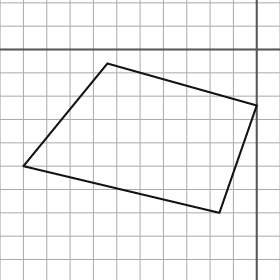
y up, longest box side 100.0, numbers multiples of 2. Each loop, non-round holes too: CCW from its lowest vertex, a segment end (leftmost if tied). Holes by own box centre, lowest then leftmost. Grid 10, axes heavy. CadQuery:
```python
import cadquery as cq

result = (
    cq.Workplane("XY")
    .moveTo(-16.0, -70.0)
    .lineTo(0.0, -24.0)
    .lineTo(-64.0, -6.0)
    .lineTo(-100.0, -50.0)
    .close()
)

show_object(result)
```